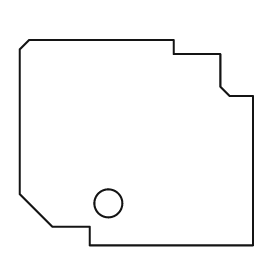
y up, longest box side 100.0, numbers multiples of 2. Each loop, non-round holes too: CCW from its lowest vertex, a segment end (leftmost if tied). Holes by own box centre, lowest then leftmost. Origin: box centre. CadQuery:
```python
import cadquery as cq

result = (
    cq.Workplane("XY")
    .moveTo(-20.0, -44.0)
    .lineTo(50.0, -44.0)
    .lineTo(50.0, 20.0)
    .lineTo(40.0, 20.0)
    .lineTo(36.0, 24.0)
    .lineTo(36.0, 38.0)
    .lineTo(16.0, 38.0)
    .lineTo(16.0, 44.0)
    .lineTo(-46.0, 44.0)
    .lineTo(-50.0, 40.0)
    .lineTo(-50.0, -22.0)
    .lineTo(-36.0, -36.0)
    .lineTo(-20.0, -36.0)
    .close()
    .moveTo(-12.0, -26.0)
    .circle(6.0)
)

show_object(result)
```